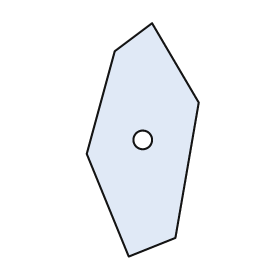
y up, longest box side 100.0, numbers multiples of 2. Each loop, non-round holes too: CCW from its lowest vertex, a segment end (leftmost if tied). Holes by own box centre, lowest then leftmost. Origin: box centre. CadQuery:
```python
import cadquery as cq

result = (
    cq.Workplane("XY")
    .moveTo(-6.0, -50.0)
    .lineTo(14.0, -42.0)
    .lineTo(24.0, 16.0)
    .lineTo(4.0, 50.0)
    .lineTo(-12.0, 38.0)
    .lineTo(-24.0, -6.0)
    .close()
    .moveTo(0.0, 0.0)
    .circle(4.0)
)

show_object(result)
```